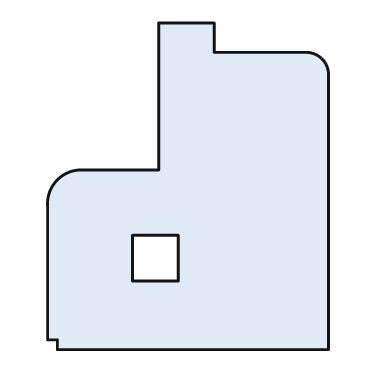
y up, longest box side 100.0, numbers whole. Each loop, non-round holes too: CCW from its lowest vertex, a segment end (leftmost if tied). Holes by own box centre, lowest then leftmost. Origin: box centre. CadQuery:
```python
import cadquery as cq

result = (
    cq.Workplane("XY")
    .moveTo(-40.0, -50.0)
    .lineTo(43.0, -50.0)
    .lineTo(43.0, 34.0)
    .threePointArc((41.0, 39.0), (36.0, 41.0))
    .lineTo(8.0, 41.0)
    .lineTo(8.0, 50.0)
    .lineTo(-9.0, 50.0)
    .lineTo(-9.0, 5.0)
    .lineTo(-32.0, 5.0)
    .threePointArc((-40.0, 2.0), (-43.0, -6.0))
    .lineTo(-43.0, -47.0)
    .lineTo(-40.0, -47.0)
    .close()
    .moveTo(-17.0, -29.0)
    .lineTo(-3.0, -29.0)
    .lineTo(-3.0, -15.0)
    .lineTo(-17.0, -15.0)
    .close()
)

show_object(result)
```